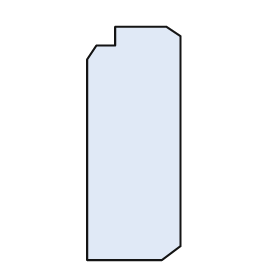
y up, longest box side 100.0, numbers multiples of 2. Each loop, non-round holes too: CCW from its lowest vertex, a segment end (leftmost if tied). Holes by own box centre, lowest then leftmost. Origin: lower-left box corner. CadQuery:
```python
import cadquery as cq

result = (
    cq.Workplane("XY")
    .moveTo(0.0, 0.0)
    .lineTo(32.0, 0.0)
    .lineTo(40.0, 6.0)
    .lineTo(40.0, 96.0)
    .lineTo(34.0, 100.0)
    .lineTo(12.0, 100.0)
    .lineTo(12.0, 92.0)
    .lineTo(4.0, 92.0)
    .lineTo(0.0, 86.0)
    .close()
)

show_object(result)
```